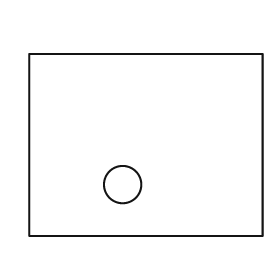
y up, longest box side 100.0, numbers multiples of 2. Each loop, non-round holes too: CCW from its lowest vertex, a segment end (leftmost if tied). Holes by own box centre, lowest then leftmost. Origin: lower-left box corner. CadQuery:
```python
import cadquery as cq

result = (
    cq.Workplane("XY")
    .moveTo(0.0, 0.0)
    .lineTo(100.0, 0.0)
    .lineTo(100.0, 78.0)
    .lineTo(0.0, 78.0)
    .close()
    .moveTo(40.0, 22.0)
    .circle(8.0)
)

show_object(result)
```